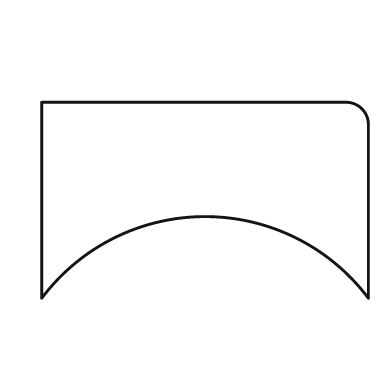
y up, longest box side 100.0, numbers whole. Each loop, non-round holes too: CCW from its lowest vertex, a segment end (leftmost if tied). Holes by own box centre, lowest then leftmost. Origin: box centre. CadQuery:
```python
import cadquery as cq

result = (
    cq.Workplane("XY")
    .moveTo(-50.0, -30.0)
    .threePointArc((0.0, -5.0), (50.0, -30.0))
    .lineTo(50.0, 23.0)
    .threePointArc((48.0, 28.0), (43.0, 30.0))
    .lineTo(-50.0, 30.0)
    .close()
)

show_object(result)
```